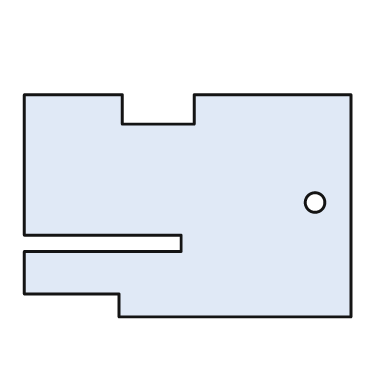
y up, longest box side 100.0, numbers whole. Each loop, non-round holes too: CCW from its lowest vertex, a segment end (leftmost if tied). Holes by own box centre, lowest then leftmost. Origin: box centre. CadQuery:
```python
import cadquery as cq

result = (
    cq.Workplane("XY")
    .moveTo(-21.0, -34.0)
    .lineTo(50.0, -34.0)
    .lineTo(50.0, 34.0)
    .lineTo(2.0, 34.0)
    .lineTo(2.0, 25.0)
    .lineTo(-20.0, 25.0)
    .lineTo(-20.0, 34.0)
    .lineTo(-50.0, 34.0)
    .lineTo(-50.0, -9.0)
    .lineTo(-2.0, -9.0)
    .lineTo(-2.0, -14.0)
    .lineTo(-50.0, -14.0)
    .lineTo(-50.0, -27.0)
    .lineTo(-21.0, -27.0)
    .close()
    .moveTo(39.0, 1.0)
    .circle(3.0)
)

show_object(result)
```